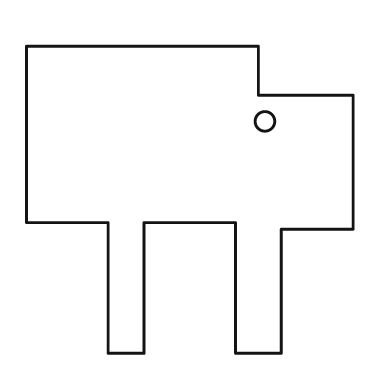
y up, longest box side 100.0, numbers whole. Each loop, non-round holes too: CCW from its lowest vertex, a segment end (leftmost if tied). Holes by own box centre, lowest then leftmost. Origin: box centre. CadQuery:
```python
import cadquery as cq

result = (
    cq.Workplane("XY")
    .moveTo(-25.0, -47.0)
    .lineTo(-14.0, -47.0)
    .lineTo(-14.0, -7.0)
    .lineTo(14.0, -7.0)
    .lineTo(14.0, -47.0)
    .lineTo(28.0, -47.0)
    .lineTo(28.0, -9.0)
    .lineTo(50.0, -9.0)
    .lineTo(50.0, 32.0)
    .lineTo(21.0, 32.0)
    .lineTo(21.0, 47.0)
    .lineTo(-50.0, 47.0)
    .lineTo(-50.0, -7.0)
    .lineTo(-25.0, -7.0)
    .close()
    .moveTo(23.0, 24.0)
    .circle(3.0)
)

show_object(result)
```